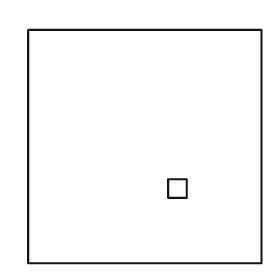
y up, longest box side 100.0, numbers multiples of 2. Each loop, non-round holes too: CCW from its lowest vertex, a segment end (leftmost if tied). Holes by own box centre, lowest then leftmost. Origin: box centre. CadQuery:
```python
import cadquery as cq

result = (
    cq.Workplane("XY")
    .moveTo(-50.0, -50.0)
    .lineTo(50.0, -50.0)
    .lineTo(50.0, 50.0)
    .lineTo(-50.0, 50.0)
    .close()
    .moveTo(10.0, -22.0)
    .lineTo(18.0, -22.0)
    .lineTo(18.0, -14.0)
    .lineTo(10.0, -14.0)
    .close()
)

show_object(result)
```